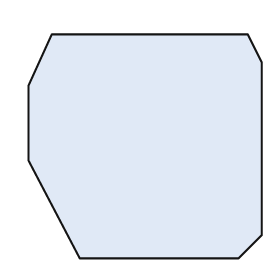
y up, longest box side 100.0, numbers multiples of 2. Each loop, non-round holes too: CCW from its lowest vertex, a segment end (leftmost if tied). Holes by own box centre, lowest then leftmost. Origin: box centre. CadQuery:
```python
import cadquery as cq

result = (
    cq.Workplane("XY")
    .moveTo(-28.0, -48.0)
    .lineTo(40.0, -48.0)
    .lineTo(50.0, -38.0)
    .lineTo(50.0, 36.0)
    .lineTo(44.0, 48.0)
    .lineTo(-40.0, 48.0)
    .lineTo(-50.0, 26.0)
    .lineTo(-50.0, -6.0)
    .close()
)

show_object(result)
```